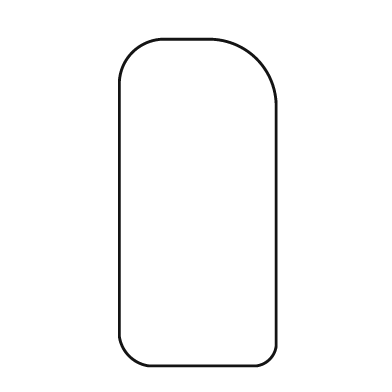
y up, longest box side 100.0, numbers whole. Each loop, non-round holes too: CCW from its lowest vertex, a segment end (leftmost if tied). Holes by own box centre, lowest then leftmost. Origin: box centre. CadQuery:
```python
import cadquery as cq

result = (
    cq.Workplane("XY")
    .moveTo(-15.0, -50.0)
    .lineTo(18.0, -50.0)
    .threePointArc((22.0, -48.0), (24.0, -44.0))
    .lineTo(24.0, 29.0)
    .threePointArc((18.0, 44.0), (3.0, 50.0))
    .lineTo(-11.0, 50.0)
    .threePointArc((-20.0, 46.0), (-24.0, 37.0))
    .lineTo(-24.0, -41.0)
    .threePointArc((-21.0, -47.0), (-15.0, -50.0))
    .close()
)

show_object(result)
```